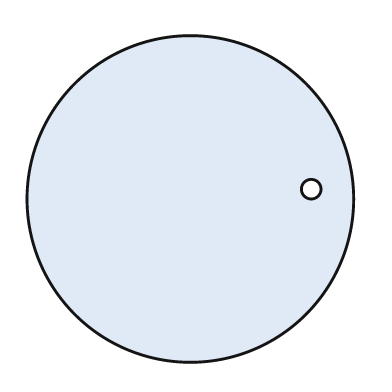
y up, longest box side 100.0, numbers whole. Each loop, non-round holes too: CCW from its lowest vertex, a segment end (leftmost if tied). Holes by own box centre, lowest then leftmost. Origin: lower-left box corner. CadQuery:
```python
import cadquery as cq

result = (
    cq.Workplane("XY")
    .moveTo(50.0, 50.0)
    .circle(50.0)
    .moveTo(87.0, 53.0)
    .circle(3.0)
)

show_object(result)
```